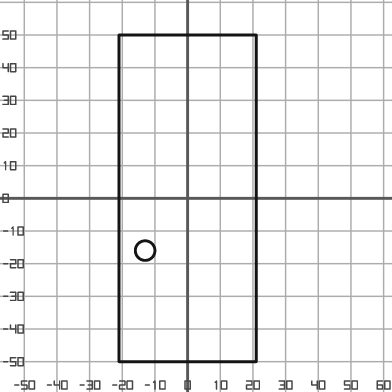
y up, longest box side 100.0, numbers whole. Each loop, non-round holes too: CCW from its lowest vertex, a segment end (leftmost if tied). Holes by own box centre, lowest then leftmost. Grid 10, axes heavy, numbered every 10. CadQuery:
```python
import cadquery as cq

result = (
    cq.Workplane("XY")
    .moveTo(-21.0, -50.0)
    .lineTo(21.0, -50.0)
    .lineTo(21.0, 50.0)
    .lineTo(-21.0, 50.0)
    .close()
    .moveTo(-13.0, -16.0)
    .circle(3.0)
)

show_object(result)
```